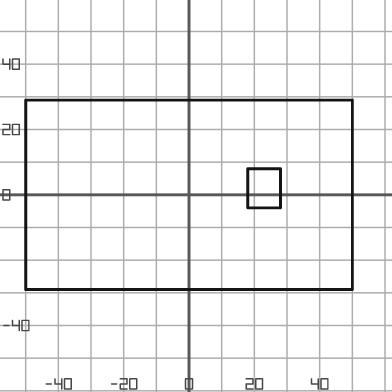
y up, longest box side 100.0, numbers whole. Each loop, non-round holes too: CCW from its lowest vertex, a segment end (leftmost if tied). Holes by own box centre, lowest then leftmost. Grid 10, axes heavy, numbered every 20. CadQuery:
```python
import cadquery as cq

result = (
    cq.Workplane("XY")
    .moveTo(-50.0, -29.0)
    .lineTo(50.0, -29.0)
    .lineTo(50.0, 29.0)
    .lineTo(-50.0, 29.0)
    .close()
    .moveTo(18.0, -4.0)
    .lineTo(28.0, -4.0)
    .lineTo(28.0, 8.0)
    .lineTo(18.0, 8.0)
    .close()
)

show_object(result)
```